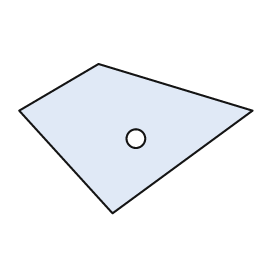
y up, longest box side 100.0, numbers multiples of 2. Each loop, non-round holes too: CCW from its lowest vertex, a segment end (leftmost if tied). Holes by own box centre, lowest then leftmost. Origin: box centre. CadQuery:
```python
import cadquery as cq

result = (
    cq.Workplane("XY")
    .moveTo(-10.0, -32.0)
    .lineTo(50.0, 12.0)
    .lineTo(-16.0, 32.0)
    .lineTo(-50.0, 12.0)
    .close()
    .moveTo(0.0, 0.0)
    .circle(4.0)
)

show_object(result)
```